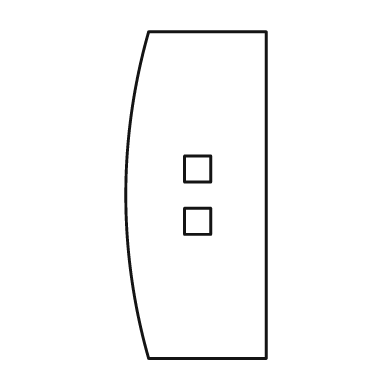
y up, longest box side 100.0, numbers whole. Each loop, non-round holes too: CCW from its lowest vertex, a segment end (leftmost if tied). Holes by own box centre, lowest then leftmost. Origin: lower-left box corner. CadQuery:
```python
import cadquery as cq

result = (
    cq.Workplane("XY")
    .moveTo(7.0, 0.0)
    .lineTo(43.0, 0.0)
    .lineTo(43.0, 100.0)
    .lineTo(7.0, 100.0)
    .threePointArc((0.0, 50.0), (7.0, 0.0))
    .close()
    .moveTo(18.0, 38.0)
    .lineTo(26.0, 38.0)
    .lineTo(26.0, 46.0)
    .lineTo(18.0, 46.0)
    .close()
    .moveTo(18.0, 54.0)
    .lineTo(26.0, 54.0)
    .lineTo(26.0, 62.0)
    .lineTo(18.0, 62.0)
    .close()
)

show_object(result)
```